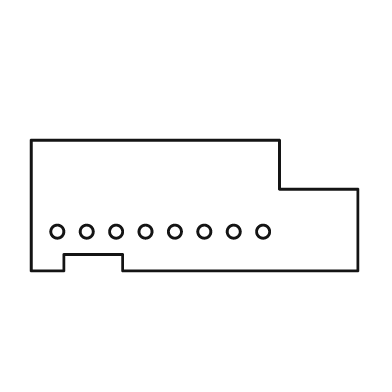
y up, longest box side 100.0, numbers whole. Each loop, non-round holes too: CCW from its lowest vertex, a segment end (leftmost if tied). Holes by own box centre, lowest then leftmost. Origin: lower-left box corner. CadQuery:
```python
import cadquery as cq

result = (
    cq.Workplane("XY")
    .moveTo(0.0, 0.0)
    .lineTo(10.0, 0.0)
    .lineTo(10.0, 5.0)
    .lineTo(28.0, 5.0)
    .lineTo(28.0, 0.0)
    .lineTo(100.0, 0.0)
    .lineTo(100.0, 25.0)
    .lineTo(76.0, 25.0)
    .lineTo(76.0, 40.0)
    .lineTo(0.0, 40.0)
    .close()
    .moveTo(8.0, 12.0)
    .circle(2.0)
    .moveTo(17.0, 12.0)
    .circle(2.0)
    .moveTo(26.0, 12.0)
    .circle(2.0)
    .moveTo(35.0, 12.0)
    .circle(2.0)
    .moveTo(44.0, 12.0)
    .circle(2.0)
    .moveTo(53.0, 12.0)
    .circle(2.0)
    .moveTo(62.0, 12.0)
    .circle(2.0)
    .moveTo(71.0, 12.0)
    .circle(2.0)
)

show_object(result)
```